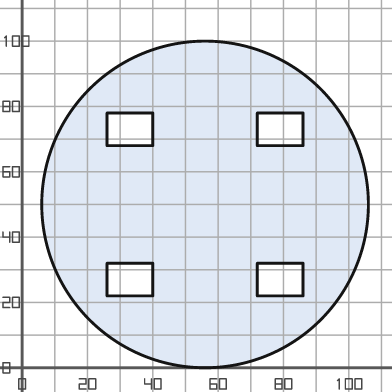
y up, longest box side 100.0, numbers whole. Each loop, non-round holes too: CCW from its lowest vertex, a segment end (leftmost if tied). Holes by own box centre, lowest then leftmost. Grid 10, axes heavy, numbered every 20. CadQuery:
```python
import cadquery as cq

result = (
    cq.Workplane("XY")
    .moveTo(56.0, 50.0)
    .circle(50.0)
    .moveTo(26.0, 22.0)
    .lineTo(40.0, 22.0)
    .lineTo(40.0, 32.0)
    .lineTo(26.0, 32.0)
    .close()
    .moveTo(72.0, 22.0)
    .lineTo(86.0, 22.0)
    .lineTo(86.0, 32.0)
    .lineTo(72.0, 32.0)
    .close()
    .moveTo(26.0, 68.0)
    .lineTo(40.0, 68.0)
    .lineTo(40.0, 78.0)
    .lineTo(26.0, 78.0)
    .close()
    .moveTo(72.0, 68.0)
    .lineTo(86.0, 68.0)
    .lineTo(86.0, 78.0)
    .lineTo(72.0, 78.0)
    .close()
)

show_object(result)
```